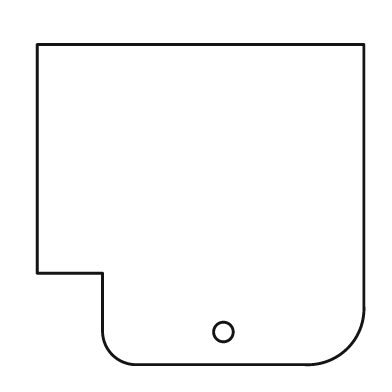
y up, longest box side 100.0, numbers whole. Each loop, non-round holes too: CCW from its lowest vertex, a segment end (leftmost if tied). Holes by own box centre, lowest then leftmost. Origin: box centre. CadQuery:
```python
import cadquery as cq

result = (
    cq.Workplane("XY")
    .moveTo(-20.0, -49.0)
    .lineTo(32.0, -49.0)
    .threePointArc((45.0, -44.0), (50.0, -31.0))
    .lineTo(50.0, 49.0)
    .lineTo(-50.0, 49.0)
    .lineTo(-50.0, -21.0)
    .lineTo(-30.0, -21.0)
    .lineTo(-30.0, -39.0)
    .threePointArc((-27.0, -46.0), (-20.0, -49.0))
    .close()
    .moveTo(7.0, -39.0)
    .circle(3.0)
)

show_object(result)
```